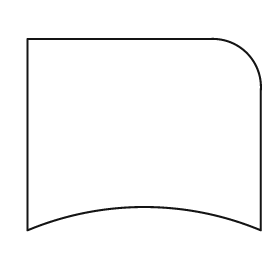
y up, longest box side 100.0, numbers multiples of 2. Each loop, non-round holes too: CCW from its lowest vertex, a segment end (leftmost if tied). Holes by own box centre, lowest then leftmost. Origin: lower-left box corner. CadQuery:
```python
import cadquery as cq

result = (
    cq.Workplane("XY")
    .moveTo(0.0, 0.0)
    .threePointArc((50.0, 10.0), (100.0, 0.0))
    .lineTo(100.0, 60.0)
    .threePointArc((94.0, 76.0), (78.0, 82.0))
    .lineTo(0.0, 82.0)
    .close()
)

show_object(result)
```